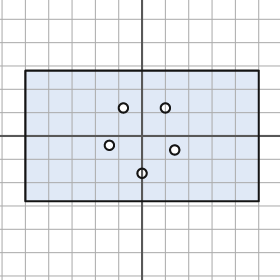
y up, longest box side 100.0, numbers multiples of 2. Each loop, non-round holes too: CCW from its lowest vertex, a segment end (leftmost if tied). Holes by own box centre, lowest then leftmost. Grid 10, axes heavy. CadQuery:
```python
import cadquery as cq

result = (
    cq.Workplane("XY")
    .moveTo(-50.0, -28.0)
    .lineTo(50.0, -28.0)
    .lineTo(50.0, 28.0)
    .lineTo(-50.0, 28.0)
    .close()
    .moveTo(0.0, -16.0)
    .circle(2.0)
    .moveTo(14.0, -6.0)
    .circle(2.0)
    .moveTo(-14.0, -4.0)
    .circle(2.0)
    .moveTo(-8.0, 12.0)
    .circle(2.0)
    .moveTo(10.0, 12.0)
    .circle(2.0)
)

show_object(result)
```